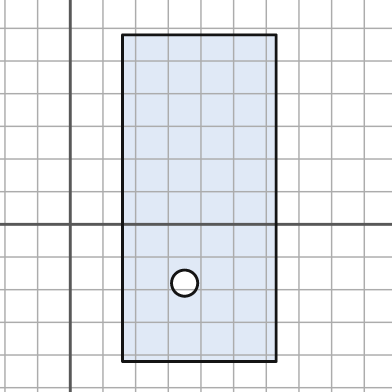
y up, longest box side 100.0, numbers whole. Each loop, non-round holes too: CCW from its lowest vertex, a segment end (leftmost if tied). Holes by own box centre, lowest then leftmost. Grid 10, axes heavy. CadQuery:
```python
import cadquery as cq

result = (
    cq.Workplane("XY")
    .moveTo(16.0, -42.0)
    .lineTo(63.0, -42.0)
    .lineTo(63.0, 58.0)
    .lineTo(16.0, 58.0)
    .close()
    .moveTo(35.0, -18.0)
    .circle(4.0)
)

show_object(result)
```